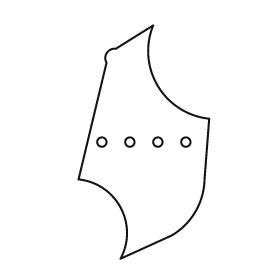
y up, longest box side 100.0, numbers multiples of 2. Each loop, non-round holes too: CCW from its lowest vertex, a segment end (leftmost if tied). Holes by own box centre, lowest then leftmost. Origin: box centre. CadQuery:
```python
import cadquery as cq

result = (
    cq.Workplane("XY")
    .moveTo(-10.0, -50.0)
    .lineTo(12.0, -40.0)
    .threePointArc((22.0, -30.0), (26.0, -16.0))
    .lineTo(28.0, 10.0)
    .threePointArc((6.0, 24.0), (4.0, 50.0))
    .lineTo(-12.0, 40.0)
    .threePointArc((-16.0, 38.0), (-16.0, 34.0))
    .lineTo(-28.0, -16.0)
    .threePointArc((-10.0, -28.0), (-10.0, -50.0))
    .close()
    .moveTo(-18.0, 0.0)
    .circle(2.0)
    .moveTo(-6.0, 0.0)
    .circle(2.0)
    .moveTo(6.0, 0.0)
    .circle(2.0)
    .moveTo(18.0, 0.0)
    .circle(2.0)
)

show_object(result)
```